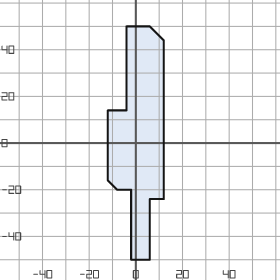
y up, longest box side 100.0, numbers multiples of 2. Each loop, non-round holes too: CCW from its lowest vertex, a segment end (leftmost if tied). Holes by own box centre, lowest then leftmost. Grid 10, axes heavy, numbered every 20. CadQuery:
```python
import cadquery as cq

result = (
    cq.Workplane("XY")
    .moveTo(-2.0, -50.0)
    .lineTo(6.0, -50.0)
    .lineTo(6.0, -24.0)
    .lineTo(12.0, -24.0)
    .lineTo(12.0, 44.0)
    .lineTo(6.0, 50.0)
    .lineTo(-4.0, 50.0)
    .lineTo(-4.0, 14.0)
    .lineTo(-12.0, 14.0)
    .lineTo(-12.0, -16.0)
    .lineTo(-8.0, -20.0)
    .lineTo(-2.0, -20.0)
    .close()
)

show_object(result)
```